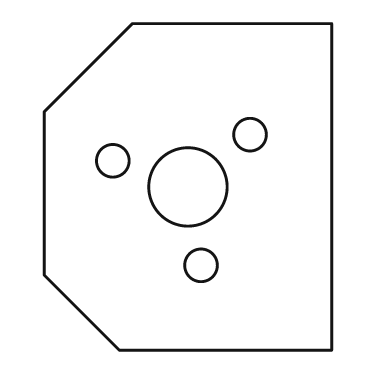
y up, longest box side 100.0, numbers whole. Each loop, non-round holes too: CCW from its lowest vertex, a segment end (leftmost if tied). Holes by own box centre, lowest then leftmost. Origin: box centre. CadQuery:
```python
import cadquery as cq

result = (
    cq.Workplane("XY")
    .moveTo(-21.0, -50.0)
    .lineTo(44.0, -50.0)
    .lineTo(44.0, 50.0)
    .lineTo(-17.0, 50.0)
    .lineTo(-44.0, 23.0)
    .lineTo(-44.0, -27.0)
    .close()
    .moveTo(4.0, -24.0)
    .circle(5.0)
    .moveTo(0.0, 0.0)
    .circle(12.0)
    .moveTo(-23.0, 8.0)
    .circle(5.0)
    .moveTo(19.0, 16.0)
    .circle(5.0)
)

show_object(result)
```